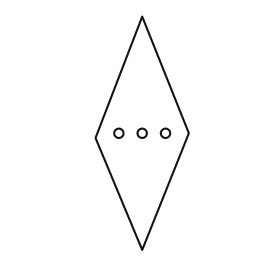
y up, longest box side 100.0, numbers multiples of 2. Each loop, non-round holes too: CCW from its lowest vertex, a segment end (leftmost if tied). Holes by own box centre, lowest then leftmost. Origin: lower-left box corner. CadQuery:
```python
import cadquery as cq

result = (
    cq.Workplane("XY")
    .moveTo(20.0, 0.0)
    .lineTo(40.0, 50.0)
    .lineTo(20.0, 100.0)
    .lineTo(0.0, 48.0)
    .close()
    .moveTo(10.0, 50.0)
    .circle(2.0)
    .moveTo(20.0, 50.0)
    .circle(2.0)
    .moveTo(30.0, 50.0)
    .circle(2.0)
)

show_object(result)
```